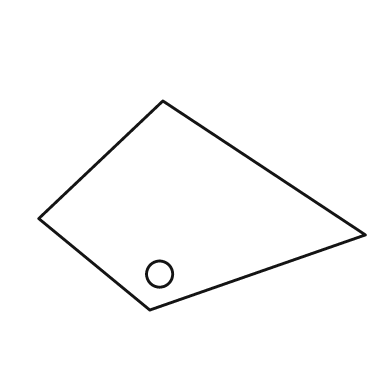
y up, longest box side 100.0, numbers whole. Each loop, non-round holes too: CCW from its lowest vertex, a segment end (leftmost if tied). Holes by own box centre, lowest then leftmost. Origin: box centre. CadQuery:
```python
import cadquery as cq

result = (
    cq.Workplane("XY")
    .moveTo(-16.0, -32.0)
    .lineTo(50.0, -9.0)
    .lineTo(-12.0, 32.0)
    .lineTo(-50.0, -4.0)
    .close()
    .moveTo(-13.0, -21.0)
    .circle(4.0)
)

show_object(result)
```